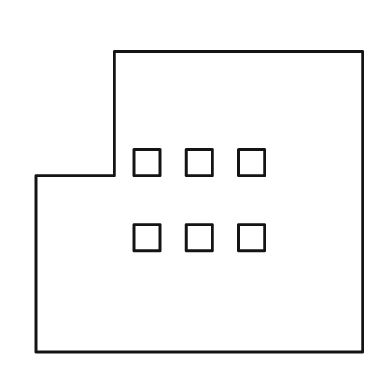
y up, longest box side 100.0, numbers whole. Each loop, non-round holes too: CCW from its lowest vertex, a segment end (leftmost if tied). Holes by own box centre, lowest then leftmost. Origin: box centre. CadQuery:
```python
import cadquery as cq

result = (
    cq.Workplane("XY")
    .moveTo(-50.0, -46.0)
    .lineTo(50.0, -46.0)
    .lineTo(50.0, 46.0)
    .lineTo(-26.0, 46.0)
    .lineTo(-26.0, 8.0)
    .lineTo(-50.0, 8.0)
    .close()
    .moveTo(-20.0, -15.0)
    .lineTo(-12.0, -15.0)
    .lineTo(-12.0, -7.0)
    .lineTo(-20.0, -7.0)
    .close()
    .moveTo(-4.0, -15.0)
    .lineTo(4.0, -15.0)
    .lineTo(4.0, -7.0)
    .lineTo(-4.0, -7.0)
    .close()
    .moveTo(12.0, -15.0)
    .lineTo(20.0, -15.0)
    .lineTo(20.0, -7.0)
    .lineTo(12.0, -7.0)
    .close()
    .moveTo(-20.0, 8.0)
    .lineTo(-12.0, 8.0)
    .lineTo(-12.0, 16.0)
    .lineTo(-20.0, 16.0)
    .close()
    .moveTo(-4.0, 8.0)
    .lineTo(4.0, 8.0)
    .lineTo(4.0, 16.0)
    .lineTo(-4.0, 16.0)
    .close()
    .moveTo(12.0, 8.0)
    .lineTo(20.0, 8.0)
    .lineTo(20.0, 16.0)
    .lineTo(12.0, 16.0)
    .close()
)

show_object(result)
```